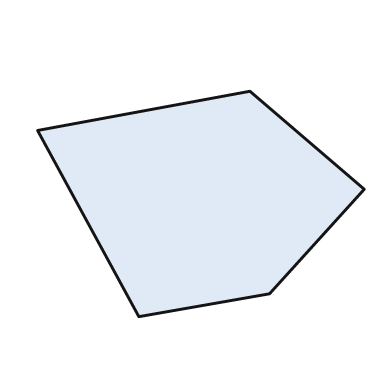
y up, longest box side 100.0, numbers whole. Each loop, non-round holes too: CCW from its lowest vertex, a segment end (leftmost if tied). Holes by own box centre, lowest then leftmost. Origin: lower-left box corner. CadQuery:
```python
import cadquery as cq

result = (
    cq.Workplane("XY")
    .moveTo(31.0, 0.0)
    .lineTo(71.0, 7.0)
    .lineTo(100.0, 39.0)
    .lineTo(65.0, 69.0)
    .lineTo(0.0, 57.0)
    .close()
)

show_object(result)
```